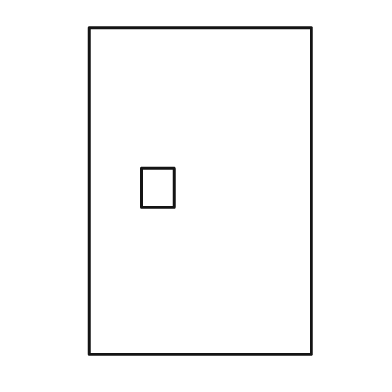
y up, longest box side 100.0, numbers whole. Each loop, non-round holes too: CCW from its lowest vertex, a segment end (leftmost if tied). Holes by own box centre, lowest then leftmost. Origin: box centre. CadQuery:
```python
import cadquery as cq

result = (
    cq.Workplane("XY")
    .moveTo(-34.0, -50.0)
    .lineTo(34.0, -50.0)
    .lineTo(34.0, 50.0)
    .lineTo(-34.0, 50.0)
    .close()
    .moveTo(-18.0, -5.0)
    .lineTo(-8.0, -5.0)
    .lineTo(-8.0, 7.0)
    .lineTo(-18.0, 7.0)
    .close()
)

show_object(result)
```